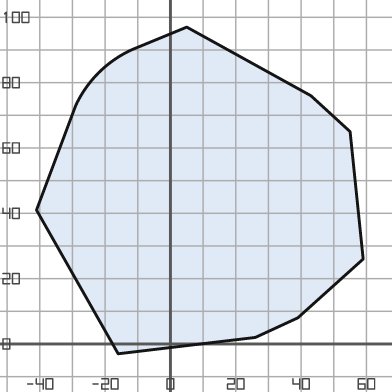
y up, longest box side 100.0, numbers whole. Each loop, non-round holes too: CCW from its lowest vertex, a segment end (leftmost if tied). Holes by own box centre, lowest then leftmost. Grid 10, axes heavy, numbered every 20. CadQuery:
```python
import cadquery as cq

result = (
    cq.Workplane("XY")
    .moveTo(-16.0, -3.0)
    .lineTo(26.0, 2.0)
    .lineTo(39.0, 8.0)
    .lineTo(59.0, 26.0)
    .lineTo(55.0, 65.0)
    .lineTo(43.0, 76.0)
    .lineTo(5.0, 97.0)
    .lineTo(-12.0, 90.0)
    .threePointArc((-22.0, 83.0), (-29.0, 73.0))
    .lineTo(-41.0, 41.0)
    .close()
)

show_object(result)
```